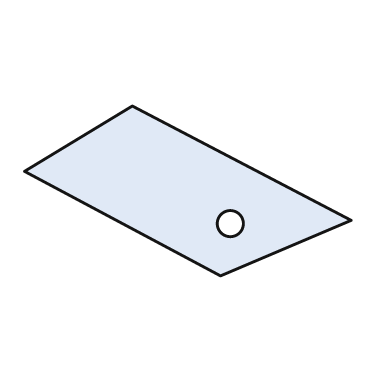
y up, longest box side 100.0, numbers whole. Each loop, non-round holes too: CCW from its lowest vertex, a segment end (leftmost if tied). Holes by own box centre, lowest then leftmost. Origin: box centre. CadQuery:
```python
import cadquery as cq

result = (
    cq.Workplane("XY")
    .moveTo(10.0, -26.0)
    .lineTo(50.0, -9.0)
    .lineTo(-17.0, 26.0)
    .lineTo(-50.0, 6.0)
    .close()
    .moveTo(13.0, -10.0)
    .circle(4.0)
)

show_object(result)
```